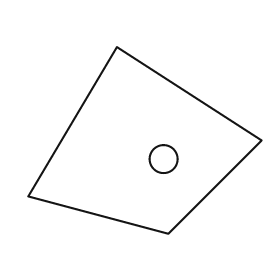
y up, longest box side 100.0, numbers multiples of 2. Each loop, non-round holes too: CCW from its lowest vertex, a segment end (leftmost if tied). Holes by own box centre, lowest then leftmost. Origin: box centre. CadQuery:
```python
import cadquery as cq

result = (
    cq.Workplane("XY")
    .moveTo(10.0, -40.0)
    .lineTo(50.0, 0.0)
    .lineTo(-12.0, 40.0)
    .lineTo(-50.0, -24.0)
    .close()
    .moveTo(8.0, -8.0)
    .circle(6.0)
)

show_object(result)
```